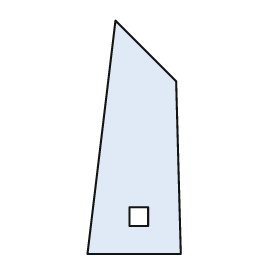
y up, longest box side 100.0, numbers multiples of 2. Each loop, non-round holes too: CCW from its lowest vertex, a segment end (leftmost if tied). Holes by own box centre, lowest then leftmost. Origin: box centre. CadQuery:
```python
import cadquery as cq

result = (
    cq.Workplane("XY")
    .moveTo(-20.0, -50.0)
    .lineTo(20.0, -50.0)
    .lineTo(18.0, 24.0)
    .lineTo(-8.0, 50.0)
    .close()
    .moveTo(-2.0, -38.0)
    .lineTo(6.0, -38.0)
    .lineTo(6.0, -30.0)
    .lineTo(-2.0, -30.0)
    .close()
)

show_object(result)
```